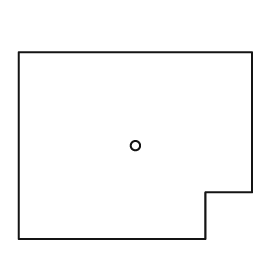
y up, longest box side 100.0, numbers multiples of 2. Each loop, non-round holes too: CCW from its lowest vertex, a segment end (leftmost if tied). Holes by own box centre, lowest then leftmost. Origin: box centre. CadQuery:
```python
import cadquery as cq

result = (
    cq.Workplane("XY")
    .moveTo(-50.0, -40.0)
    .lineTo(30.0, -40.0)
    .lineTo(30.0, -20.0)
    .lineTo(50.0, -20.0)
    .lineTo(50.0, 40.0)
    .lineTo(-50.0, 40.0)
    .close()
    .moveTo(0.0, 0.0)
    .circle(2.0)
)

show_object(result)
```